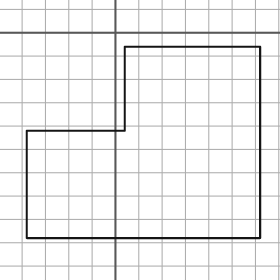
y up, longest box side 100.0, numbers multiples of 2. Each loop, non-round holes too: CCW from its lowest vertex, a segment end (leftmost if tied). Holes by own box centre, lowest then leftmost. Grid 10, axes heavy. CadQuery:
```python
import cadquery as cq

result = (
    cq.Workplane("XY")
    .moveTo(-38.0, -88.0)
    .lineTo(62.0, -88.0)
    .lineTo(62.0, -6.0)
    .lineTo(4.0, -6.0)
    .lineTo(4.0, -42.0)
    .lineTo(-38.0, -42.0)
    .close()
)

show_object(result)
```